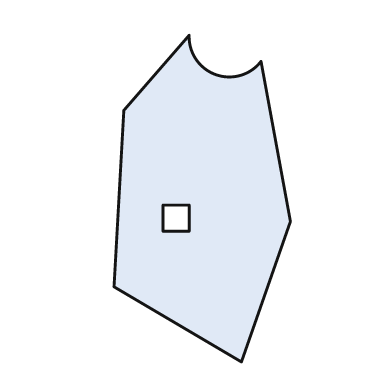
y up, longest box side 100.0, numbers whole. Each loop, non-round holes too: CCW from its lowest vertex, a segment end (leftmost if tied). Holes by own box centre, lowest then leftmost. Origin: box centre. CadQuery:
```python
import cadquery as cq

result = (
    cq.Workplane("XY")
    .moveTo(12.0, -50.0)
    .lineTo(27.0, -7.0)
    .lineTo(18.0, 42.0)
    .threePointArc((4.0, 38.0), (-4.0, 50.0))
    .lineTo(-24.0, 27.0)
    .lineTo(-27.0, -27.0)
    .close()
    .moveTo(-12.0, -10.0)
    .lineTo(-4.0, -10.0)
    .lineTo(-4.0, -2.0)
    .lineTo(-12.0, -2.0)
    .close()
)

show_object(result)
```